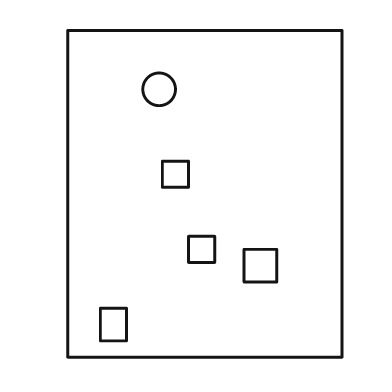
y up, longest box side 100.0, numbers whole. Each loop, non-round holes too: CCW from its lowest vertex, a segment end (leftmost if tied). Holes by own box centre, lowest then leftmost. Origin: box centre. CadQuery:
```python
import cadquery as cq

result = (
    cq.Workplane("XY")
    .moveTo(-42.0, -50.0)
    .lineTo(42.0, -50.0)
    .lineTo(42.0, 50.0)
    .lineTo(-42.0, 50.0)
    .close()
    .moveTo(-32.0, -45.0)
    .lineTo(-24.0, -45.0)
    .lineTo(-24.0, -35.0)
    .lineTo(-32.0, -35.0)
    .close()
    .moveTo(12.0, -27.0)
    .lineTo(22.0, -27.0)
    .lineTo(22.0, -17.0)
    .lineTo(12.0, -17.0)
    .close()
    .moveTo(-5.0, -21.0)
    .lineTo(3.0, -21.0)
    .lineTo(3.0, -13.0)
    .lineTo(-5.0, -13.0)
    .close()
    .moveTo(-13.0, 2.0)
    .lineTo(-5.0, 2.0)
    .lineTo(-5.0, 10.0)
    .lineTo(-13.0, 10.0)
    .close()
    .moveTo(-14.0, 32.0)
    .circle(5.0)
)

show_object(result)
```